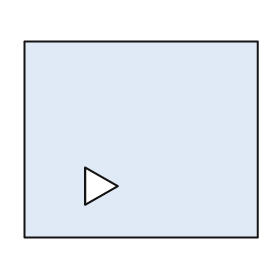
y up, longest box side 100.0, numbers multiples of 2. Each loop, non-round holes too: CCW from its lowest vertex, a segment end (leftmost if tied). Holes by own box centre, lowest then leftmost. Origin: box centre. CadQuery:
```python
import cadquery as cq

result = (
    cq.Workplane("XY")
    .moveTo(-50.0, -42.0)
    .lineTo(50.0, -42.0)
    .lineTo(50.0, 42.0)
    .lineTo(-50.0, 42.0)
    .close()
    .moveTo(-24.0, -28.0)
    .lineTo(-10.0, -20.0)
    .lineTo(-24.0, -12.0)
    .close()
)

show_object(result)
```